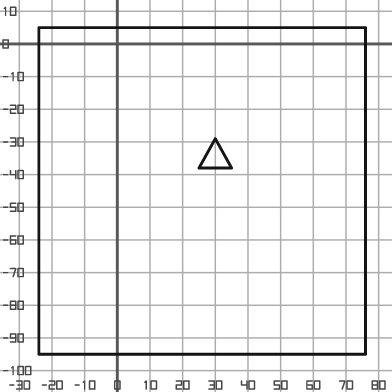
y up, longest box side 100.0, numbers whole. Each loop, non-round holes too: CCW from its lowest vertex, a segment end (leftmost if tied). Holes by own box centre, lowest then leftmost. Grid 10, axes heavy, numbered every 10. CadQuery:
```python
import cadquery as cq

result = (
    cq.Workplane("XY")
    .moveTo(-24.0, -95.0)
    .lineTo(76.0, -95.0)
    .lineTo(76.0, 5.0)
    .lineTo(-24.0, 5.0)
    .close()
    .moveTo(25.0, -38.0)
    .lineTo(35.0, -38.0)
    .lineTo(30.0, -29.0)
    .close()
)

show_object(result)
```